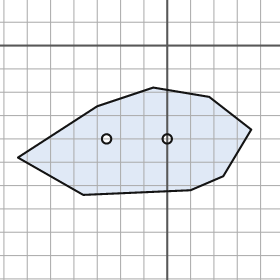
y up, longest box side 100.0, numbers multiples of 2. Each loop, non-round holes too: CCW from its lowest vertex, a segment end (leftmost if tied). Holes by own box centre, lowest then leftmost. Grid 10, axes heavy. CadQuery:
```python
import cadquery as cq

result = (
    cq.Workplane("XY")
    .moveTo(-36.0, -64.0)
    .lineTo(10.0, -62.0)
    .lineTo(24.0, -56.0)
    .lineTo(36.0, -36.0)
    .lineTo(18.0, -22.0)
    .lineTo(-6.0, -18.0)
    .lineTo(-30.0, -26.0)
    .lineTo(-64.0, -48.0)
    .close()
    .moveTo(-26.0, -40.0)
    .circle(2.0)
    .moveTo(0.0, -40.0)
    .circle(2.0)
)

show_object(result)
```